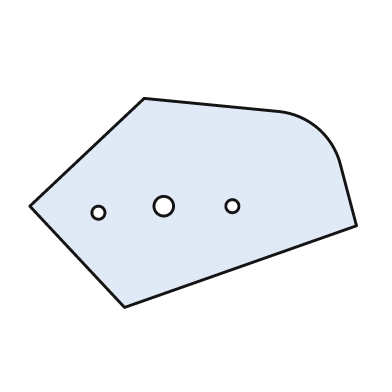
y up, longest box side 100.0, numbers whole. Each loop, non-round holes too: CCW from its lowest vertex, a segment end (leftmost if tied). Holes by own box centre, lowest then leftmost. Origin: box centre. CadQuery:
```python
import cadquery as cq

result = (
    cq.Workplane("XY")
    .moveTo(-21.0, -32.0)
    .lineTo(50.0, -7.0)
    .lineTo(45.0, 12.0)
    .threePointArc((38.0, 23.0), (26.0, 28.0))
    .lineTo(-15.0, 32.0)
    .lineTo(-50.0, -1.0)
    .close()
    .moveTo(-29.0, -3.0)
    .circle(2.0)
    .moveTo(-9.0, -1.0)
    .circle(3.0)
    .moveTo(12.0, -1.0)
    .circle(2.0)
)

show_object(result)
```